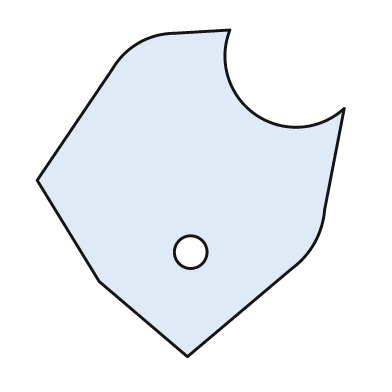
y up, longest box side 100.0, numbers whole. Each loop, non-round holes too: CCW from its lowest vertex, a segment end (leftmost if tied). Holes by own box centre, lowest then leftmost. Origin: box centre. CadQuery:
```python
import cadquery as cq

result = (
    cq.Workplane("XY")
    .moveTo(-1.0, -50.0)
    .lineTo(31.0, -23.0)
    .threePointArc((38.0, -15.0), (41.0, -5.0))
    .lineTo(47.0, 26.0)
    .threePointArc((20.0, 24.0), (12.0, 50.0))
    .lineTo(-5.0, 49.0)
    .threePointArc((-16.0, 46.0), (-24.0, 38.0))
    .lineTo(-47.0, 4.0)
    .lineTo(-28.0, -27.0)
    .close()
    .moveTo(0.0, -18.0)
    .circle(5.0)
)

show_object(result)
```